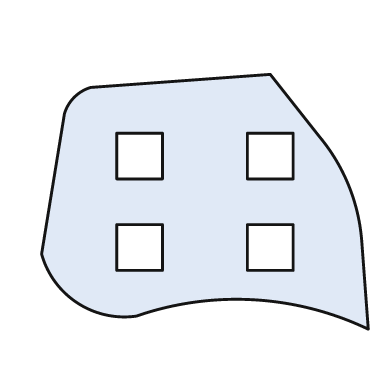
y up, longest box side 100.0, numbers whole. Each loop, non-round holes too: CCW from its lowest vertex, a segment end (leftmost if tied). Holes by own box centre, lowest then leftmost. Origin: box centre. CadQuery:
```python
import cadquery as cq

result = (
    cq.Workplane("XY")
    .moveTo(50.0, -39.0)
    .lineTo(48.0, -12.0)
    .threePointArc((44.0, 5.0), (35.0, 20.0))
    .lineTo(20.0, 39.0)
    .lineTo(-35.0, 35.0)
    .threePointArc((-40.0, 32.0), (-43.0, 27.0))
    .lineTo(-50.0, -16.0)
    .threePointArc((-39.0, -31.0), (-21.0, -35.0))
    .threePointArc((15.0, -30.0), (50.0, -39.0))
    .close()
    .moveTo(-27.0, -21.0)
    .lineTo(-13.0, -21.0)
    .lineTo(-13.0, -7.0)
    .lineTo(-27.0, -7.0)
    .close()
    .moveTo(13.0, -21.0)
    .lineTo(27.0, -21.0)
    .lineTo(27.0, -7.0)
    .lineTo(13.0, -7.0)
    .close()
    .moveTo(-27.0, 7.0)
    .lineTo(-13.0, 7.0)
    .lineTo(-13.0, 21.0)
    .lineTo(-27.0, 21.0)
    .close()
    .moveTo(13.0, 7.0)
    .lineTo(27.0, 7.0)
    .lineTo(27.0, 21.0)
    .lineTo(13.0, 21.0)
    .close()
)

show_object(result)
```